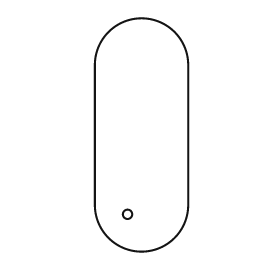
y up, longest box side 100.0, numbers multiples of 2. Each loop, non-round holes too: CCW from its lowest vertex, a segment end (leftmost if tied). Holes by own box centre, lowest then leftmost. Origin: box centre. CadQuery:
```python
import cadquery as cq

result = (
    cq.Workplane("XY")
    .moveTo(-20.0, -30.0)
    .threePointArc((0.0, -50.0), (20.0, -30.0))
    .lineTo(20.0, 30.0)
    .threePointArc((0.0, 50.0), (-20.0, 30.0))
    .close()
    .moveTo(-6.0, -34.0)
    .circle(2.0)
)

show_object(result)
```